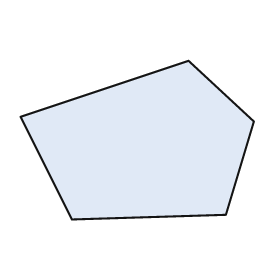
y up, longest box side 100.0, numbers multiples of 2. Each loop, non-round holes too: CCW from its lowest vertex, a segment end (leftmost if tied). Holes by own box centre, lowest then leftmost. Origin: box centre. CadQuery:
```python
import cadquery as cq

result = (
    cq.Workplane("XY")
    .moveTo(-28.0, -34.0)
    .lineTo(38.0, -32.0)
    .lineTo(50.0, 8.0)
    .lineTo(22.0, 34.0)
    .lineTo(-50.0, 10.0)
    .close()
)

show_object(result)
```